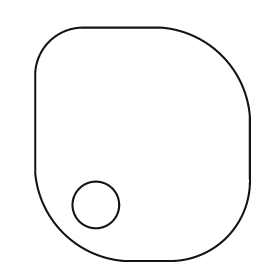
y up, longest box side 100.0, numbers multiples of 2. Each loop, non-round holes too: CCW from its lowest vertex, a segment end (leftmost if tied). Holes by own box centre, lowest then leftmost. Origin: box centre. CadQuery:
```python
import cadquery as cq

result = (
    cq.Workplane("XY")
    .moveTo(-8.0, -50.0)
    .lineTo(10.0, -50.0)
    .threePointArc((36.0, -40.0), (46.0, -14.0))
    .lineTo(46.0, 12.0)
    .threePointArc((34.0, 38.0), (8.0, 50.0))
    .lineTo(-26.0, 50.0)
    .threePointArc((-40.0, 44.0), (-46.0, 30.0))
    .lineTo(-46.0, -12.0)
    .threePointArc((-34.0, -38.0), (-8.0, -50.0))
    .close()
    .moveTo(-20.0, -26.0)
    .circle(10.0)
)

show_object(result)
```